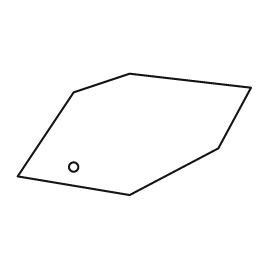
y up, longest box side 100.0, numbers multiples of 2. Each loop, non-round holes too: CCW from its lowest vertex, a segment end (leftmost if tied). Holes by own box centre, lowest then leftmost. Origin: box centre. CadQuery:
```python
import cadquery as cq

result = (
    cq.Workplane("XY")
    .moveTo(-2.0, -26.0)
    .lineTo(36.0, -6.0)
    .lineTo(50.0, 20.0)
    .lineTo(-2.0, 26.0)
    .lineTo(-26.0, 18.0)
    .lineTo(-50.0, -18.0)
    .close()
    .moveTo(-26.0, -14.0)
    .circle(2.0)
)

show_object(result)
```